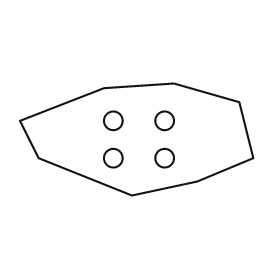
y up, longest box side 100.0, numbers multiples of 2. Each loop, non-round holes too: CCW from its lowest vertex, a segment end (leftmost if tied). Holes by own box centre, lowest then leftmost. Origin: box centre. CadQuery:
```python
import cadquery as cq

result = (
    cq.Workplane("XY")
    .moveTo(-2.0, -24.0)
    .lineTo(26.0, -18.0)
    .lineTo(50.0, -8.0)
    .lineTo(44.0, 16.0)
    .lineTo(16.0, 24.0)
    .lineTo(-14.0, 22.0)
    .lineTo(-50.0, 8.0)
    .lineTo(-42.0, -8.0)
    .close()
    .moveTo(-10.0, -8.0)
    .circle(4.0)
    .moveTo(12.0, -8.0)
    .circle(4.0)
    .moveTo(-10.0, 8.0)
    .circle(4.0)
    .moveTo(12.0, 8.0)
    .circle(4.0)
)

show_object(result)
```